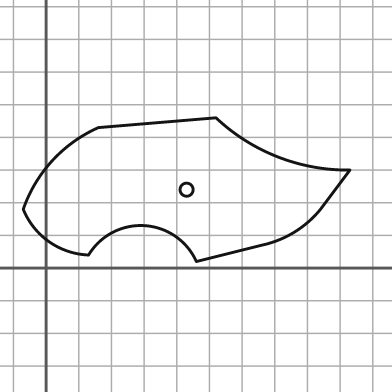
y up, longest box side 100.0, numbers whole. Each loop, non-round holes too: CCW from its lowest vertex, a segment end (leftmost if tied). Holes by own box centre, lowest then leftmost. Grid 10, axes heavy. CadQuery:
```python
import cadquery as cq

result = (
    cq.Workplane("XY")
    .moveTo(46.0, 2.0)
    .lineTo(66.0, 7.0)
    .threePointArc((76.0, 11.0), (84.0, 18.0))
    .lineTo(93.0, 30.0)
    .threePointArc((71.0, 34.0), (52.0, 46.0))
    .lineTo(16.0, 43.0)
    .threePointArc((2.0, 33.0), (-7.0, 18.0))
    .threePointArc((1.0, 8.0), (13.0, 4.0))
    .threePointArc((30.0, 13.0), (46.0, 2.0))
    .close()
    .moveTo(43.0, 24.0)
    .circle(2.0)
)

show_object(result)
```